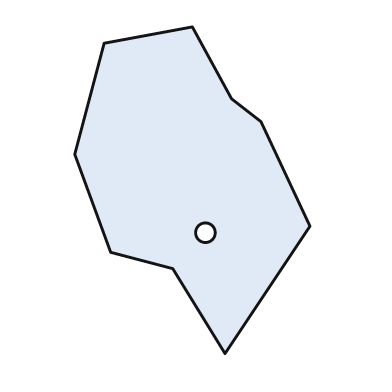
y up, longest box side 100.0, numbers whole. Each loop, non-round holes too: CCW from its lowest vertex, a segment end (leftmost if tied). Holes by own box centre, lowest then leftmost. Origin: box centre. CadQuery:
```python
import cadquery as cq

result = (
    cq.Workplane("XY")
    .moveTo(10.0, -50.0)
    .lineTo(36.0, -11.0)
    .lineTo(21.0, 21.0)
    .lineTo(12.0, 28.0)
    .lineTo(0.0, 50.0)
    .lineTo(-27.0, 45.0)
    .lineTo(-36.0, 11.0)
    .lineTo(-25.0, -19.0)
    .lineTo(-6.0, -24.0)
    .close()
    .moveTo(4.0, -13.0)
    .circle(3.0)
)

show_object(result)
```